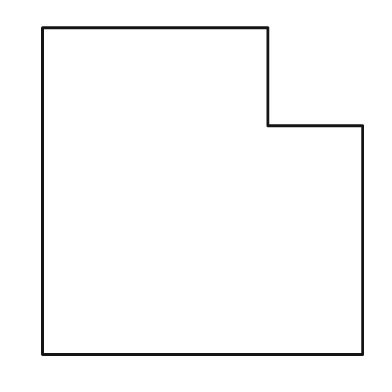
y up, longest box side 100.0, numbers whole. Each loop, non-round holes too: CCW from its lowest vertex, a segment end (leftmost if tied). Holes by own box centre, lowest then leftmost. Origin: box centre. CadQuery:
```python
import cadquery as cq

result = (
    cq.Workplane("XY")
    .moveTo(-49.0, -50.0)
    .lineTo(49.0, -50.0)
    .lineTo(49.0, 20.0)
    .lineTo(20.0, 20.0)
    .lineTo(20.0, 50.0)
    .lineTo(-49.0, 50.0)
    .close()
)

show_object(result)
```